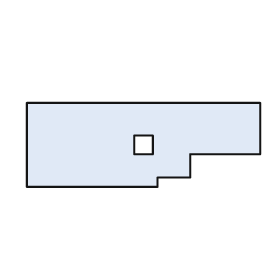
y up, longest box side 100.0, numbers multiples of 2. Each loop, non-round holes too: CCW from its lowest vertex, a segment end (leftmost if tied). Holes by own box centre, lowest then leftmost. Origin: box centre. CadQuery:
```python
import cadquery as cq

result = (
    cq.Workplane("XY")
    .moveTo(-50.0, -18.0)
    .lineTo(6.0, -18.0)
    .lineTo(6.0, -14.0)
    .lineTo(20.0, -14.0)
    .lineTo(20.0, -4.0)
    .lineTo(50.0, -4.0)
    .lineTo(50.0, 18.0)
    .lineTo(-50.0, 18.0)
    .close()
    .moveTo(-4.0, -4.0)
    .lineTo(4.0, -4.0)
    .lineTo(4.0, 4.0)
    .lineTo(-4.0, 4.0)
    .close()
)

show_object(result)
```